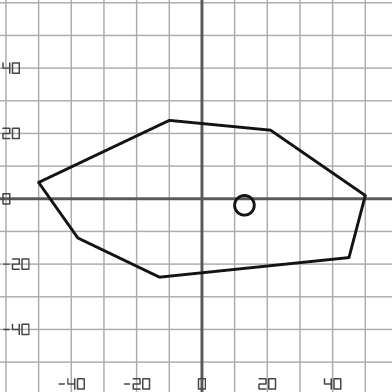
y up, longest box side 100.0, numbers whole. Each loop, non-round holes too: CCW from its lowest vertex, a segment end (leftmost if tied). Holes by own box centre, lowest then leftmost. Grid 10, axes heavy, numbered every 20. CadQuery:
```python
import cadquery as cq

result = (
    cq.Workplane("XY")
    .moveTo(-13.0, -24.0)
    .lineTo(45.0, -18.0)
    .lineTo(50.0, 1.0)
    .lineTo(21.0, 21.0)
    .lineTo(-10.0, 24.0)
    .lineTo(-50.0, 5.0)
    .lineTo(-38.0, -12.0)
    .close()
    .moveTo(13.0, -2.0)
    .circle(3.0)
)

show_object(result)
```